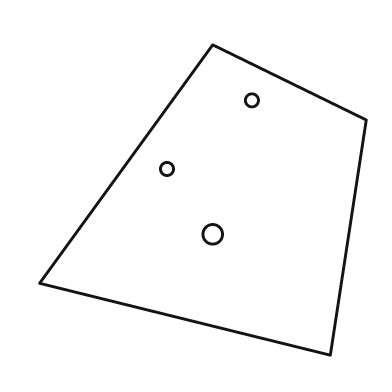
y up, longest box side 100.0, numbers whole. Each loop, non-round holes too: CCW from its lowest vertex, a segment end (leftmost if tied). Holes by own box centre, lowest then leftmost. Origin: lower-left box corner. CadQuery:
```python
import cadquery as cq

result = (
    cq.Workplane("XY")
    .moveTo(89.0, 0.0)
    .lineTo(100.0, 72.0)
    .lineTo(53.0, 95.0)
    .lineTo(0.0, 22.0)
    .close()
    .moveTo(53.0, 37.0)
    .circle(3.0)
    .moveTo(39.0, 57.0)
    .circle(2.0)
    .moveTo(65.0, 78.0)
    .circle(2.0)
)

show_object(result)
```